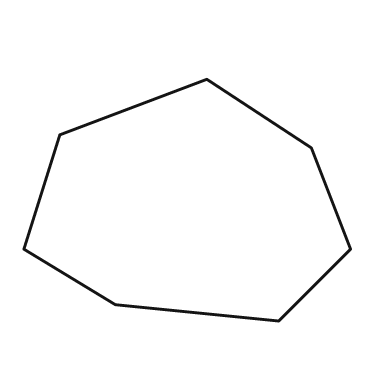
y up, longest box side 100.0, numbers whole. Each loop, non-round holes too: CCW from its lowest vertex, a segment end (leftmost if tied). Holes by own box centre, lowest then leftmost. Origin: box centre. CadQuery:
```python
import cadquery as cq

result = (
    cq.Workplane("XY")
    .moveTo(28.0, -37.0)
    .lineTo(50.0, -15.0)
    .lineTo(38.0, 16.0)
    .lineTo(6.0, 37.0)
    .lineTo(-39.0, 20.0)
    .lineTo(-50.0, -15.0)
    .lineTo(-22.0, -32.0)
    .close()
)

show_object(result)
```